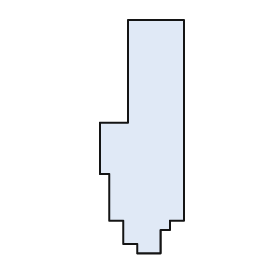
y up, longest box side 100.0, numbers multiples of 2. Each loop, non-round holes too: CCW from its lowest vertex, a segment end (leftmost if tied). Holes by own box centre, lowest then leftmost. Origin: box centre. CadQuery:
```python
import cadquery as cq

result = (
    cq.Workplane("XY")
    .moveTo(-2.0, -50.0)
    .lineTo(8.0, -50.0)
    .lineTo(8.0, -40.0)
    .lineTo(12.0, -40.0)
    .lineTo(12.0, -36.0)
    .lineTo(18.0, -36.0)
    .lineTo(18.0, 50.0)
    .lineTo(-6.0, 50.0)
    .lineTo(-6.0, 6.0)
    .lineTo(-18.0, 6.0)
    .lineTo(-18.0, -16.0)
    .lineTo(-14.0, -16.0)
    .lineTo(-14.0, -36.0)
    .lineTo(-8.0, -36.0)
    .lineTo(-8.0, -46.0)
    .lineTo(-2.0, -46.0)
    .close()
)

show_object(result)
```